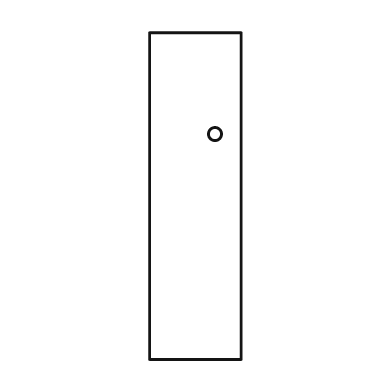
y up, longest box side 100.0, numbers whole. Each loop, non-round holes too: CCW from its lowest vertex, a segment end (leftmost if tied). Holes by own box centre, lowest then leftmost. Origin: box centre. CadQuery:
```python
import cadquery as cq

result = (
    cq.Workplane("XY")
    .moveTo(-14.0, -50.0)
    .lineTo(14.0, -50.0)
    .lineTo(14.0, 50.0)
    .lineTo(-14.0, 50.0)
    .close()
    .moveTo(6.0, 19.0)
    .circle(2.0)
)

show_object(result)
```